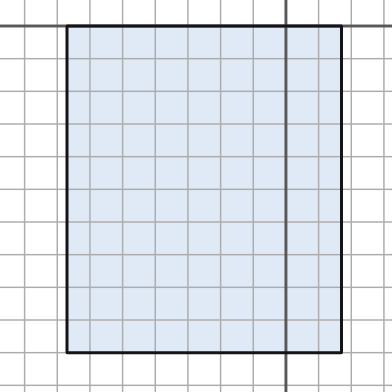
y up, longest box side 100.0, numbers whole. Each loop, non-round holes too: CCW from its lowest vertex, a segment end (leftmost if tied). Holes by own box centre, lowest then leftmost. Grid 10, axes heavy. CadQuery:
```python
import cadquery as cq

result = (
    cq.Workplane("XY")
    .moveTo(-67.0, -100.0)
    .lineTo(17.0, -100.0)
    .lineTo(17.0, 0.0)
    .lineTo(-67.0, 0.0)
    .close()
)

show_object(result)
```